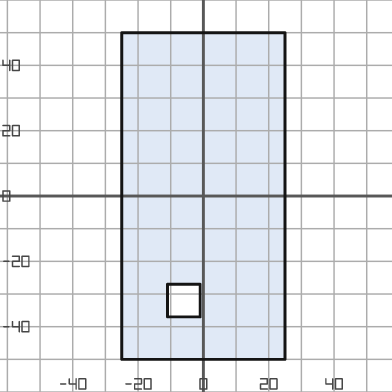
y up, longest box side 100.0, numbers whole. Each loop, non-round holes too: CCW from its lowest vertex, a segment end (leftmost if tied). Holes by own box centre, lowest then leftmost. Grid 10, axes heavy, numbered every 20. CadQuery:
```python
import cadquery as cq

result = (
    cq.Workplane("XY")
    .moveTo(-25.0, -50.0)
    .lineTo(25.0, -50.0)
    .lineTo(25.0, 50.0)
    .lineTo(-25.0, 50.0)
    .close()
    .moveTo(-11.0, -37.0)
    .lineTo(-1.0, -37.0)
    .lineTo(-1.0, -27.0)
    .lineTo(-11.0, -27.0)
    .close()
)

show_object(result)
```